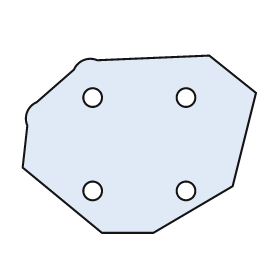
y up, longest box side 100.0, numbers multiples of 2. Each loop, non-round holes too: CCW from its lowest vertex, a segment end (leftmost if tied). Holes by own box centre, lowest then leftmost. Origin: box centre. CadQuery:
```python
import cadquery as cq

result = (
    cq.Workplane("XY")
    .moveTo(-16.0, -38.0)
    .lineTo(6.0, -38.0)
    .lineTo(40.0, -18.0)
    .lineTo(50.0, 22.0)
    .lineTo(30.0, 38.0)
    .lineTo(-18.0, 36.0)
    .threePointArc((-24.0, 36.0), (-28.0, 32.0))
    .lineTo(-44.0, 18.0)
    .threePointArc((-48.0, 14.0), (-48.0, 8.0))
    .lineTo(-50.0, -10.0)
    .close()
    .moveTo(-20.0, -20.0)
    .circle(4.0)
    .moveTo(20.0, -20.0)
    .circle(4.0)
    .moveTo(-20.0, 20.0)
    .circle(4.0)
    .moveTo(20.0, 20.0)
    .circle(4.0)
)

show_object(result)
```